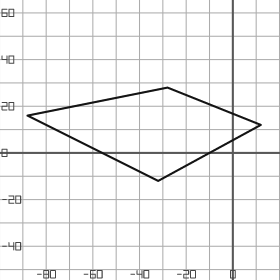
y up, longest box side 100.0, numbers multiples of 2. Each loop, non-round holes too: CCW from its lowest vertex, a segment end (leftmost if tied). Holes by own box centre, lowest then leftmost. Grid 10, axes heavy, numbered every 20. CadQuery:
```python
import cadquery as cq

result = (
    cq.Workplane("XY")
    .moveTo(-32.0, -12.0)
    .lineTo(12.0, 12.0)
    .lineTo(-28.0, 28.0)
    .lineTo(-88.0, 16.0)
    .close()
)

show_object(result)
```